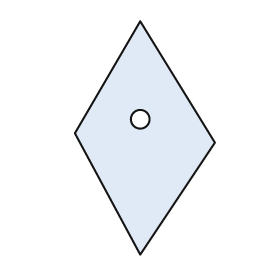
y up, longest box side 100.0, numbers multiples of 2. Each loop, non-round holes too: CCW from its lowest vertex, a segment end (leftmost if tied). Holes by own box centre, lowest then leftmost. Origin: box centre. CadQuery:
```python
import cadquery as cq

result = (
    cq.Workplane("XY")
    .moveTo(-2.0, -50.0)
    .lineTo(30.0, -2.0)
    .lineTo(-2.0, 50.0)
    .lineTo(-30.0, 2.0)
    .close()
    .moveTo(-2.0, 8.0)
    .circle(4.0)
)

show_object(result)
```